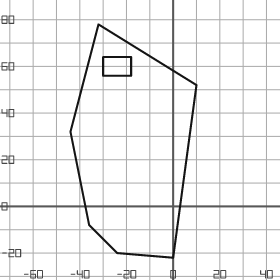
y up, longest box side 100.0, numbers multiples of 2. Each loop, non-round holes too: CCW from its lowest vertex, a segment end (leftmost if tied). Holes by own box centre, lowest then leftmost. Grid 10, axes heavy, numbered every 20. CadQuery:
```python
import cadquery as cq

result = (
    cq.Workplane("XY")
    .moveTo(0.0, -22.0)
    .lineTo(10.0, 52.0)
    .lineTo(-32.0, 78.0)
    .lineTo(-44.0, 32.0)
    .lineTo(-36.0, -8.0)
    .lineTo(-24.0, -20.0)
    .close()
    .moveTo(-30.0, 56.0)
    .lineTo(-18.0, 56.0)
    .lineTo(-18.0, 64.0)
    .lineTo(-30.0, 64.0)
    .close()
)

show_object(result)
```